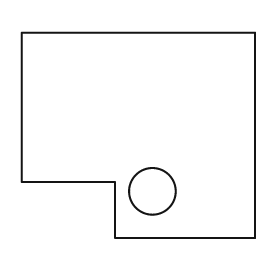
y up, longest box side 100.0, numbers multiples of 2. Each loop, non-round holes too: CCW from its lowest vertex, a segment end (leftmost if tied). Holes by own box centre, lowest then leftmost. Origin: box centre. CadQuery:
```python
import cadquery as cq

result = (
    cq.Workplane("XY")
    .moveTo(-10.0, -44.0)
    .lineTo(50.0, -44.0)
    .lineTo(50.0, 44.0)
    .lineTo(-50.0, 44.0)
    .lineTo(-50.0, -20.0)
    .lineTo(-10.0, -20.0)
    .close()
    .moveTo(6.0, -24.0)
    .circle(10.0)
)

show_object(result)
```